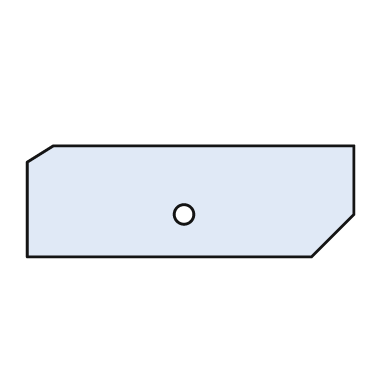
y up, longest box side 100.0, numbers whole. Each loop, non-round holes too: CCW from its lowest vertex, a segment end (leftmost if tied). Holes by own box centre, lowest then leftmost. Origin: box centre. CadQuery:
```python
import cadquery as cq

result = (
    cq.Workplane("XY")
    .moveTo(-50.0, -17.0)
    .lineTo(37.0, -17.0)
    .lineTo(50.0, -4.0)
    .lineTo(50.0, 17.0)
    .lineTo(-42.0, 17.0)
    .lineTo(-50.0, 12.0)
    .close()
    .moveTo(-2.0, -4.0)
    .circle(3.0)
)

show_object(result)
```